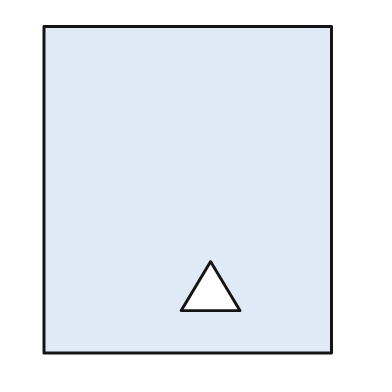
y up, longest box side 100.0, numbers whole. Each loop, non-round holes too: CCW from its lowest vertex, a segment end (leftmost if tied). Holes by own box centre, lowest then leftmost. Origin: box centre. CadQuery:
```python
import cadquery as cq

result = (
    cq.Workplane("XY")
    .moveTo(-44.0, -50.0)
    .lineTo(44.0, -50.0)
    .lineTo(44.0, 50.0)
    .lineTo(-44.0, 50.0)
    .close()
    .moveTo(-2.0, -37.0)
    .lineTo(16.0, -37.0)
    .lineTo(7.0, -22.0)
    .close()
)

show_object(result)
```